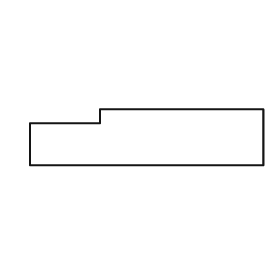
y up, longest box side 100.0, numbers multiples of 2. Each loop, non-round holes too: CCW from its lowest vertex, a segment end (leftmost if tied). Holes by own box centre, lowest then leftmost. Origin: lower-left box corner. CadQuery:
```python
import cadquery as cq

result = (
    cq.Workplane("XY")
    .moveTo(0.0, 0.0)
    .lineTo(100.0, 0.0)
    .lineTo(100.0, 24.0)
    .lineTo(30.0, 24.0)
    .lineTo(30.0, 18.0)
    .lineTo(0.0, 18.0)
    .close()
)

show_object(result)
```